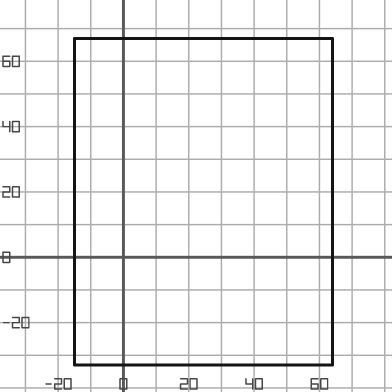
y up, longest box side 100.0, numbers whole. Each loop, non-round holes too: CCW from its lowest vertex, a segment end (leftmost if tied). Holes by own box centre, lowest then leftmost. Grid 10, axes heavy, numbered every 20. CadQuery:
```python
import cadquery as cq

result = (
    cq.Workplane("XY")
    .moveTo(-15.0, -33.0)
    .lineTo(64.0, -33.0)
    .lineTo(64.0, 67.0)
    .lineTo(-15.0, 67.0)
    .close()
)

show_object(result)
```